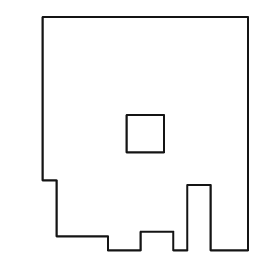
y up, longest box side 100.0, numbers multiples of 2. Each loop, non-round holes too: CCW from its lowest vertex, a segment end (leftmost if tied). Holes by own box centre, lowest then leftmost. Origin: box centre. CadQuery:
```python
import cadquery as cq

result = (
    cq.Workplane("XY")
    .moveTo(-16.0, -50.0)
    .lineTo(-2.0, -50.0)
    .lineTo(-2.0, -42.0)
    .lineTo(12.0, -42.0)
    .lineTo(12.0, -50.0)
    .lineTo(18.0, -50.0)
    .lineTo(18.0, -22.0)
    .lineTo(28.0, -22.0)
    .lineTo(28.0, -50.0)
    .lineTo(44.0, -50.0)
    .lineTo(44.0, 50.0)
    .lineTo(-44.0, 50.0)
    .lineTo(-44.0, -20.0)
    .lineTo(-38.0, -20.0)
    .lineTo(-38.0, -44.0)
    .lineTo(-16.0, -44.0)
    .close()
    .moveTo(-8.0, -8.0)
    .lineTo(8.0, -8.0)
    .lineTo(8.0, 8.0)
    .lineTo(-8.0, 8.0)
    .close()
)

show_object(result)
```